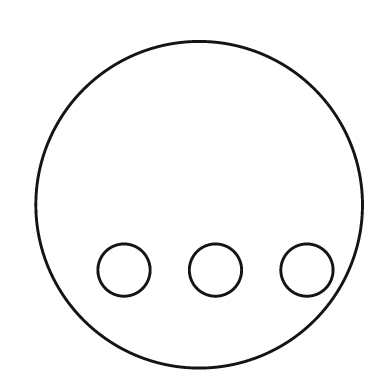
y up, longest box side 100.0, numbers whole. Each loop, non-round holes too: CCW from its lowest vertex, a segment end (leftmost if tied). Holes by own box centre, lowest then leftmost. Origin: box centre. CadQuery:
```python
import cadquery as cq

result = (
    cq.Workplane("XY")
    .moveTo(0.0, 0.0)
    .circle(50.0)
    .moveTo(-23.0, -20.0)
    .circle(8.0)
    .moveTo(5.0, -20.0)
    .circle(8.0)
    .moveTo(33.0, -20.0)
    .circle(8.0)
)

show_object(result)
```